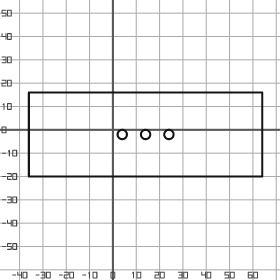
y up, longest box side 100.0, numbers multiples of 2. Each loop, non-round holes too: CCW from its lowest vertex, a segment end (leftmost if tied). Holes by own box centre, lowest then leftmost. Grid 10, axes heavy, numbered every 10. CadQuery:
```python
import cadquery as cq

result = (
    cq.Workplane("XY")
    .moveTo(-36.0, -20.0)
    .lineTo(64.0, -20.0)
    .lineTo(64.0, 16.0)
    .lineTo(-36.0, 16.0)
    .close()
    .moveTo(4.0, -2.0)
    .circle(2.0)
    .moveTo(14.0, -2.0)
    .circle(2.0)
    .moveTo(24.0, -2.0)
    .circle(2.0)
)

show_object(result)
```